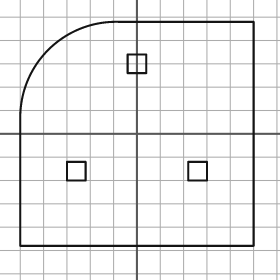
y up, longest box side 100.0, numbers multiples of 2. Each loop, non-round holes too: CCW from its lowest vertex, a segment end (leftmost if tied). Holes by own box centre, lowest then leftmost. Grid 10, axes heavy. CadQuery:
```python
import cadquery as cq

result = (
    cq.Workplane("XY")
    .moveTo(-50.0, -48.0)
    .lineTo(50.0, -48.0)
    .lineTo(50.0, 48.0)
    .lineTo(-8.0, 48.0)
    .threePointArc((-38.0, 36.0), (-50.0, 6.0))
    .close()
    .moveTo(-30.0, -20.0)
    .lineTo(-22.0, -20.0)
    .lineTo(-22.0, -12.0)
    .lineTo(-30.0, -12.0)
    .close()
    .moveTo(22.0, -20.0)
    .lineTo(30.0, -20.0)
    .lineTo(30.0, -12.0)
    .lineTo(22.0, -12.0)
    .close()
    .moveTo(-4.0, 26.0)
    .lineTo(4.0, 26.0)
    .lineTo(4.0, 34.0)
    .lineTo(-4.0, 34.0)
    .close()
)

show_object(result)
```